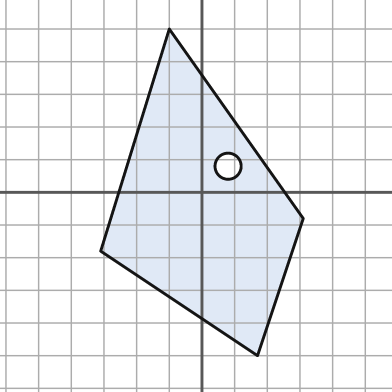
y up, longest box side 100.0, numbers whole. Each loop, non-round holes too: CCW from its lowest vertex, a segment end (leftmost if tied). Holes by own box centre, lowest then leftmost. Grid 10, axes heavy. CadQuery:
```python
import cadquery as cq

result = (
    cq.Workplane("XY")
    .moveTo(17.0, -50.0)
    .lineTo(31.0, -8.0)
    .lineTo(-10.0, 50.0)
    .lineTo(-31.0, -18.0)
    .close()
    .moveTo(8.0, 8.0)
    .circle(4.0)
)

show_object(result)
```